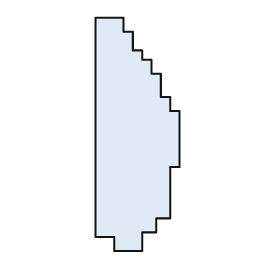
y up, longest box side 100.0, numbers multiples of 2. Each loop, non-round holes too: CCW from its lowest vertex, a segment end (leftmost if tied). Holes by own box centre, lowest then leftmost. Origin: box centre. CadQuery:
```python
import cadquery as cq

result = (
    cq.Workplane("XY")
    .moveTo(-10.0, -50.0)
    .lineTo(2.0, -50.0)
    .lineTo(2.0, -42.0)
    .lineTo(8.0, -42.0)
    .lineTo(8.0, -36.0)
    .lineTo(14.0, -36.0)
    .lineTo(14.0, -14.0)
    .lineTo(18.0, -14.0)
    .lineTo(18.0, 10.0)
    .lineTo(14.0, 10.0)
    .lineTo(14.0, 16.0)
    .lineTo(10.0, 16.0)
    .lineTo(10.0, 26.0)
    .lineTo(6.0, 26.0)
    .lineTo(6.0, 32.0)
    .lineTo(2.0, 32.0)
    .lineTo(2.0, 36.0)
    .lineTo(-2.0, 36.0)
    .lineTo(-2.0, 44.0)
    .lineTo(-6.0, 44.0)
    .lineTo(-6.0, 50.0)
    .lineTo(-18.0, 50.0)
    .lineTo(-18.0, -44.0)
    .lineTo(-10.0, -44.0)
    .close()
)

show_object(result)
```